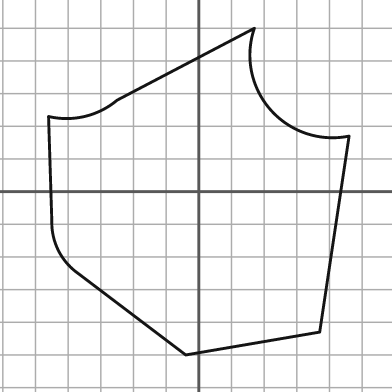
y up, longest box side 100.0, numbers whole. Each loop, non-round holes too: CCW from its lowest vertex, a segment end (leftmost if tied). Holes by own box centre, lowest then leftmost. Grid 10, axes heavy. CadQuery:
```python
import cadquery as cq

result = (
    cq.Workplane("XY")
    .moveTo(-4.0, -50.0)
    .lineTo(37.0, -43.0)
    .lineTo(46.0, 17.0)
    .threePointArc((22.0, 25.0), (17.0, 50.0))
    .lineTo(-25.0, 28.0)
    .threePointArc((-35.0, 23.0), (-46.0, 23.0))
    .lineTo(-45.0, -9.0)
    .threePointArc((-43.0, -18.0), (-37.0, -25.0))
    .close()
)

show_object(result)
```